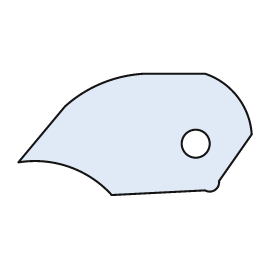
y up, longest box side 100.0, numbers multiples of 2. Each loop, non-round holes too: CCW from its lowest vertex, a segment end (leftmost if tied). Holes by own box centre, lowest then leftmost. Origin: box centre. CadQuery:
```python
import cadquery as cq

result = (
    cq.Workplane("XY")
    .moveTo(-10.0, -26.0)
    .lineTo(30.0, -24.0)
    .threePointArc((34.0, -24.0), (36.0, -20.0))
    .lineTo(50.0, 0.0)
    .threePointArc((44.0, 16.0), (30.0, 26.0))
    .lineTo(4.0, 26.0)
    .threePointArc((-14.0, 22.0), (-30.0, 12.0))
    .lineTo(-50.0, -12.0)
    .threePointArc((-28.0, -14.0), (-10.0, -26.0))
    .close()
    .moveTo(26.0, -4.0)
    .circle(6.0)
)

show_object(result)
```